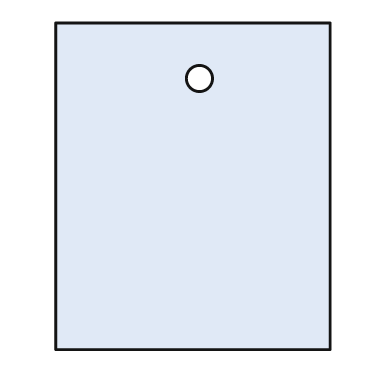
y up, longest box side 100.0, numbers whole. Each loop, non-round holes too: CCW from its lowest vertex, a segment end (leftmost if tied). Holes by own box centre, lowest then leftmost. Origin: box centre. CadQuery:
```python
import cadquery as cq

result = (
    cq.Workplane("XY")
    .moveTo(-42.0, -50.0)
    .lineTo(42.0, -50.0)
    .lineTo(42.0, 50.0)
    .lineTo(-42.0, 50.0)
    .close()
    .moveTo(2.0, 33.0)
    .circle(4.0)
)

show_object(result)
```